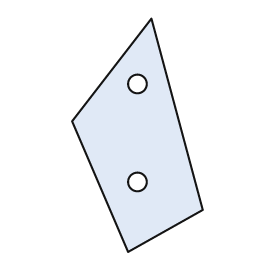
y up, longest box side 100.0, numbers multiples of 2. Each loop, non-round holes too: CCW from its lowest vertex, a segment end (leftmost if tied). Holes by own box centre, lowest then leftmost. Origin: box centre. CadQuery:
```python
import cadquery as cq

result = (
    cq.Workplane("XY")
    .moveTo(-4.0, -50.0)
    .lineTo(28.0, -32.0)
    .lineTo(6.0, 50.0)
    .lineTo(-28.0, 6.0)
    .close()
    .moveTo(0.0, -20.0)
    .circle(4.0)
    .moveTo(0.0, 22.0)
    .circle(4.0)
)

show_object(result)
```